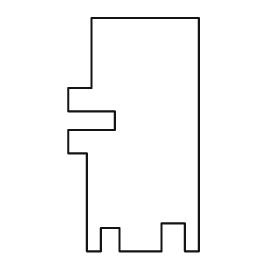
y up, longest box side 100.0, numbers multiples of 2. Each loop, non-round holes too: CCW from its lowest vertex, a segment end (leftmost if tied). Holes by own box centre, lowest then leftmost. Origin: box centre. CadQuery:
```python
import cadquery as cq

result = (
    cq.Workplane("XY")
    .moveTo(-20.0, -50.0)
    .lineTo(-14.0, -50.0)
    .lineTo(-14.0, -40.0)
    .lineTo(-6.0, -40.0)
    .lineTo(-6.0, -50.0)
    .lineTo(12.0, -50.0)
    .lineTo(12.0, -38.0)
    .lineTo(22.0, -38.0)
    .lineTo(22.0, -50.0)
    .lineTo(28.0, -50.0)
    .lineTo(28.0, 50.0)
    .lineTo(-18.0, 50.0)
    .lineTo(-18.0, 20.0)
    .lineTo(-28.0, 20.0)
    .lineTo(-28.0, 10.0)
    .lineTo(-8.0, 10.0)
    .lineTo(-8.0, 2.0)
    .lineTo(-28.0, 2.0)
    .lineTo(-28.0, -8.0)
    .lineTo(-20.0, -8.0)
    .close()
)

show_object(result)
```